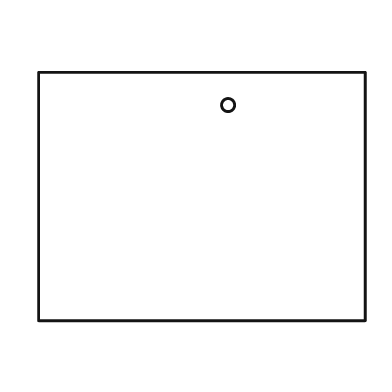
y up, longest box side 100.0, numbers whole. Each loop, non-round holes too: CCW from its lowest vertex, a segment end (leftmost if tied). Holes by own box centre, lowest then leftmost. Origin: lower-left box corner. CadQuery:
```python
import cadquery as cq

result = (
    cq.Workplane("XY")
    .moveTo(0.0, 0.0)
    .lineTo(100.0, 0.0)
    .lineTo(100.0, 76.0)
    .lineTo(0.0, 76.0)
    .close()
    .moveTo(58.0, 66.0)
    .circle(2.0)
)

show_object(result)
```